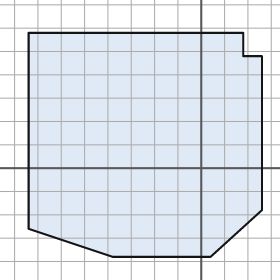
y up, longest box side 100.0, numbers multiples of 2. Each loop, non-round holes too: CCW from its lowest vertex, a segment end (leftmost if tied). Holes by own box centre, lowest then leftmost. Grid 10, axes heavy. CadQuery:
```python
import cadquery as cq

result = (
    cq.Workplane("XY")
    .moveTo(-38.0, -38.0)
    .lineTo(4.0, -38.0)
    .lineTo(26.0, -18.0)
    .lineTo(26.0, 48.0)
    .lineTo(18.0, 48.0)
    .lineTo(18.0, 58.0)
    .lineTo(-74.0, 58.0)
    .lineTo(-74.0, -26.0)
    .close()
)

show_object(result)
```